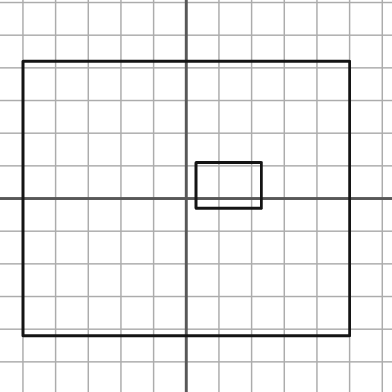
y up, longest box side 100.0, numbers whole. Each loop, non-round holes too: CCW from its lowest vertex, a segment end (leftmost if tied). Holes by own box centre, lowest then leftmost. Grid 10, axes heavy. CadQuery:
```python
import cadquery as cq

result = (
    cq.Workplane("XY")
    .moveTo(-50.0, -42.0)
    .lineTo(50.0, -42.0)
    .lineTo(50.0, 42.0)
    .lineTo(-50.0, 42.0)
    .close()
    .moveTo(3.0, -3.0)
    .lineTo(23.0, -3.0)
    .lineTo(23.0, 11.0)
    .lineTo(3.0, 11.0)
    .close()
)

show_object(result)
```